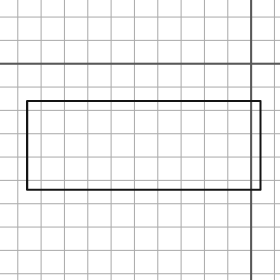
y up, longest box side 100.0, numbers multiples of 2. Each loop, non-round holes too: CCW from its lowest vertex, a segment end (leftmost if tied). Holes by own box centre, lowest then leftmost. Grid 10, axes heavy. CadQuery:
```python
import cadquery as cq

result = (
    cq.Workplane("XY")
    .moveTo(-96.0, -54.0)
    .lineTo(4.0, -54.0)
    .lineTo(4.0, -16.0)
    .lineTo(-96.0, -16.0)
    .close()
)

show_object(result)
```